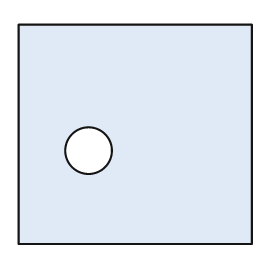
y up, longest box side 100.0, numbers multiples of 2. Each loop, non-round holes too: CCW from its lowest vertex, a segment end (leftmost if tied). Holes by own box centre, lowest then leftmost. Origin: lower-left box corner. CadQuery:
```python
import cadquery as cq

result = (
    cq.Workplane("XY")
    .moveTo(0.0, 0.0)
    .lineTo(100.0, 0.0)
    .lineTo(100.0, 94.0)
    .lineTo(0.0, 94.0)
    .close()
    .moveTo(30.0, 40.0)
    .circle(10.0)
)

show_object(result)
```